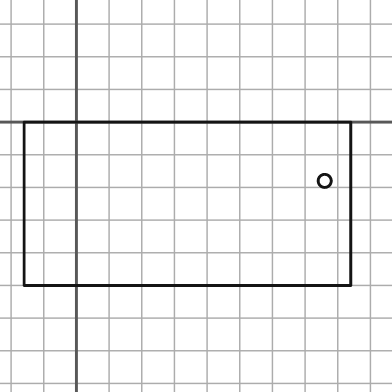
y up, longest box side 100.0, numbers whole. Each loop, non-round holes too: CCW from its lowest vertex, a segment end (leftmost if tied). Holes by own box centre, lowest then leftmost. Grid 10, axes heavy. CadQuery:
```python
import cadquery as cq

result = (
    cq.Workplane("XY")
    .moveTo(-16.0, -50.0)
    .lineTo(84.0, -50.0)
    .lineTo(84.0, 0.0)
    .lineTo(-16.0, 0.0)
    .close()
    .moveTo(76.0, -18.0)
    .circle(2.0)
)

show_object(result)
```